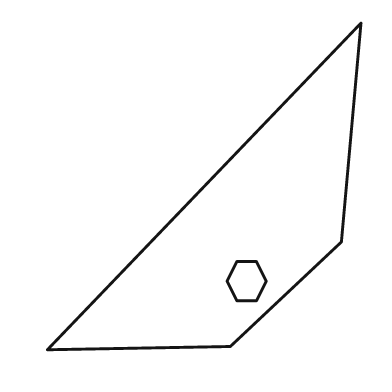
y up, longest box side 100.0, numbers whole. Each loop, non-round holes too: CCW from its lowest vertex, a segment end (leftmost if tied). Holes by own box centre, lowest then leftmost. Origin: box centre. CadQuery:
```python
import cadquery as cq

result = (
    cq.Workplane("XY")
    .moveTo(-48.0, -50.0)
    .lineTo(8.0, -49.0)
    .lineTo(42.0, -17.0)
    .lineTo(48.0, 50.0)
    .close()
    .moveTo(10.0, -35.0)
    .lineTo(16.0, -35.0)
    .lineTo(19.0, -29.0)
    .lineTo(16.0, -23.0)
    .lineTo(10.0, -23.0)
    .lineTo(7.0, -29.0)
    .close()
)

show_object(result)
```